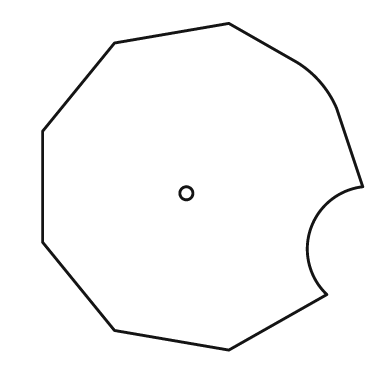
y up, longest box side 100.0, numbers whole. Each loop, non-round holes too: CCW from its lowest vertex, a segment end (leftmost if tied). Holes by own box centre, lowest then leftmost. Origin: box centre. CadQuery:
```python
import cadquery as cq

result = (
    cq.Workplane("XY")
    .moveTo(8.0, -50.0)
    .lineTo(38.0, -33.0)
    .threePointArc((33.0, -13.0), (49.0, 0.0))
    .lineTo(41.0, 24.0)
    .threePointArc((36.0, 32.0), (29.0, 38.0))
    .lineTo(8.0, 50.0)
    .lineTo(-27.0, 44.0)
    .lineTo(-49.0, 17.0)
    .lineTo(-49.0, -17.0)
    .lineTo(-27.0, -44.0)
    .close()
    .moveTo(-5.0, -2.0)
    .circle(2.0)
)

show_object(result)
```